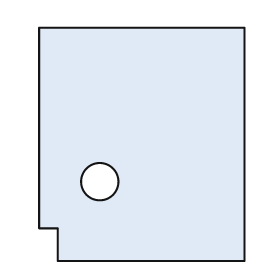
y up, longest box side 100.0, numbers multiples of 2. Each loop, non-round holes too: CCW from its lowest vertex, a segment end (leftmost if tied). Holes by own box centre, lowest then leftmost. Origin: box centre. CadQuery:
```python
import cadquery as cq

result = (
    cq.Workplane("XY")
    .moveTo(-36.0, -50.0)
    .lineTo(44.0, -50.0)
    .lineTo(44.0, 50.0)
    .lineTo(-44.0, 50.0)
    .lineTo(-44.0, -36.0)
    .lineTo(-36.0, -36.0)
    .close()
    .moveTo(-18.0, -16.0)
    .circle(8.0)
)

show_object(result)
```